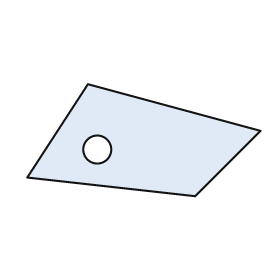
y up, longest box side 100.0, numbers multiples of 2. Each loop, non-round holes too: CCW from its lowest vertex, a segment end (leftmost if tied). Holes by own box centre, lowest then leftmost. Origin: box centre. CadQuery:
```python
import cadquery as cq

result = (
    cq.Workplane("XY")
    .moveTo(22.0, -24.0)
    .lineTo(50.0, 4.0)
    .lineTo(-24.0, 24.0)
    .lineTo(-50.0, -16.0)
    .close()
    .moveTo(-20.0, -4.0)
    .circle(6.0)
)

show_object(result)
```